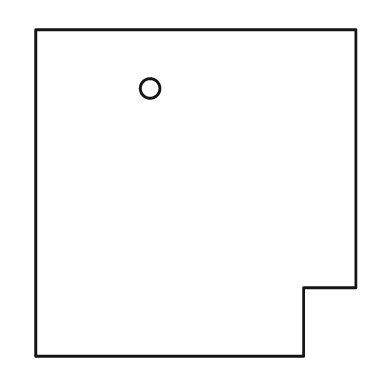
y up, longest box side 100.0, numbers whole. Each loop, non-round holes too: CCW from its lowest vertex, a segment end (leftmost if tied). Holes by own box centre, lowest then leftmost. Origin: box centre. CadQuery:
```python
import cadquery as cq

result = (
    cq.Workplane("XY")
    .moveTo(-49.0, -50.0)
    .lineTo(33.0, -50.0)
    .lineTo(33.0, -29.0)
    .lineTo(49.0, -29.0)
    .lineTo(49.0, 50.0)
    .lineTo(-49.0, 50.0)
    .close()
    .moveTo(-14.0, 32.0)
    .circle(3.0)
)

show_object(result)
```